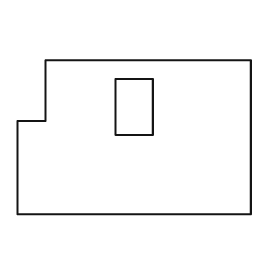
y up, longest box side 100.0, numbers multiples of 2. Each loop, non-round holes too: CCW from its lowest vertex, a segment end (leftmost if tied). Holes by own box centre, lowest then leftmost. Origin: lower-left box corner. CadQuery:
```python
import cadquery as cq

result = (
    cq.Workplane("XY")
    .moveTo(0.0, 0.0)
    .lineTo(100.0, 0.0)
    .lineTo(100.0, 66.0)
    .lineTo(12.0, 66.0)
    .lineTo(12.0, 40.0)
    .lineTo(0.0, 40.0)
    .close()
    .moveTo(42.0, 34.0)
    .lineTo(58.0, 34.0)
    .lineTo(58.0, 58.0)
    .lineTo(42.0, 58.0)
    .close()
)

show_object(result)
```